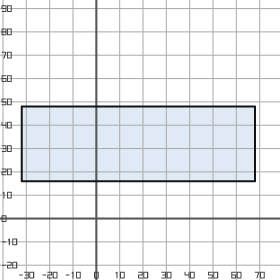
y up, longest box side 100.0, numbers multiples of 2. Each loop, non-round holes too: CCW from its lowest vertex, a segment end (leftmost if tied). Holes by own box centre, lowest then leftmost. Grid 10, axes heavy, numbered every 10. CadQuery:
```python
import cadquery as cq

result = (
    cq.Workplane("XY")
    .moveTo(-32.0, 16.0)
    .lineTo(68.0, 16.0)
    .lineTo(68.0, 48.0)
    .lineTo(-32.0, 48.0)
    .close()
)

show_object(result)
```